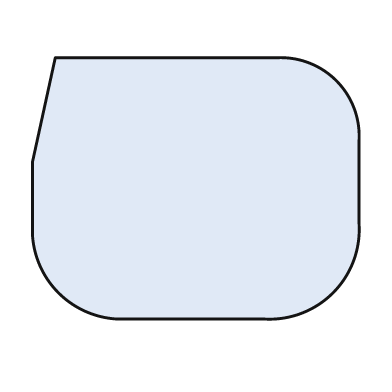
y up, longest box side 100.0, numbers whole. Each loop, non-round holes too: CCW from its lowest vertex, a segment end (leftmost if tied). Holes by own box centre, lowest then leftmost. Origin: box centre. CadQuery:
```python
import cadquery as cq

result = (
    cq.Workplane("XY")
    .moveTo(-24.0, -40.0)
    .lineTo(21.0, -40.0)
    .threePointArc((42.0, -32.0), (50.0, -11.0))
    .lineTo(50.0, 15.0)
    .threePointArc((43.0, 33.0), (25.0, 40.0))
    .lineTo(-43.0, 40.0)
    .lineTo(-50.0, 8.0)
    .lineTo(-50.0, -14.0)
    .threePointArc((-42.0, -32.0), (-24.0, -40.0))
    .close()
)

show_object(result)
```